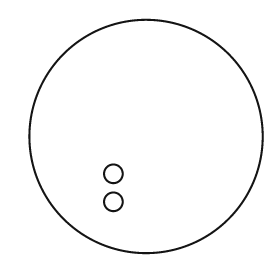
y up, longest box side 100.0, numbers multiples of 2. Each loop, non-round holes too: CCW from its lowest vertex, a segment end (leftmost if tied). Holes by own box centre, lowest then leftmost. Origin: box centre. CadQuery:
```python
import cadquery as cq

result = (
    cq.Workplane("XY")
    .moveTo(0.0, 0.0)
    .circle(50.0)
    .moveTo(-14.0, -28.0)
    .circle(4.0)
    .moveTo(-14.0, -16.0)
    .circle(4.0)
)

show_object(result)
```